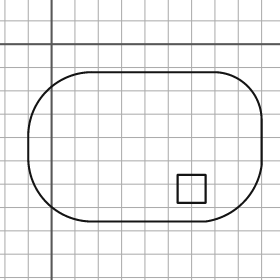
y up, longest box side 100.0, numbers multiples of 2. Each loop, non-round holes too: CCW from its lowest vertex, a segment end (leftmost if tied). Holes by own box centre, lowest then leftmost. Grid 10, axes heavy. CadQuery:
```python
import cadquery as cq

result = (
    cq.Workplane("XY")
    .moveTo(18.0, -76.0)
    .lineTo(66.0, -76.0)
    .threePointArc((82.0, -68.0), (90.0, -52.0))
    .lineTo(90.0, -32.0)
    .threePointArc((84.0, -18.0), (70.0, -12.0))
    .lineTo(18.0, -12.0)
    .threePointArc((-2.0, -20.0), (-10.0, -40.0))
    .lineTo(-10.0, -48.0)
    .threePointArc((-2.0, -68.0), (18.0, -76.0))
    .close()
    .moveTo(54.0, -68.0)
    .lineTo(66.0, -68.0)
    .lineTo(66.0, -56.0)
    .lineTo(54.0, -56.0)
    .close()
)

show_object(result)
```